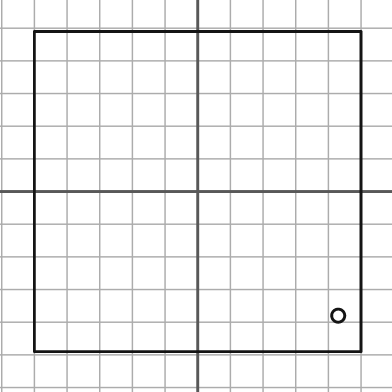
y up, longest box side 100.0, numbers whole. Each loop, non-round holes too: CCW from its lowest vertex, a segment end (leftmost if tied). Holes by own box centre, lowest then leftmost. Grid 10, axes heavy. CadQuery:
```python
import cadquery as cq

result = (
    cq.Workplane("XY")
    .moveTo(-50.0, -49.0)
    .lineTo(50.0, -49.0)
    .lineTo(50.0, 49.0)
    .lineTo(-50.0, 49.0)
    .close()
    .moveTo(43.0, -38.0)
    .circle(2.0)
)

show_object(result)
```